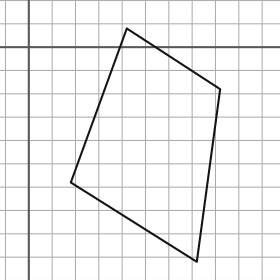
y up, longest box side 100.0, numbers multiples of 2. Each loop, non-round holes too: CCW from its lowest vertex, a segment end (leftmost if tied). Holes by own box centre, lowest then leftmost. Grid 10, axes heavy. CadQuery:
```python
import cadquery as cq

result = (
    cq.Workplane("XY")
    .moveTo(72.0, -92.0)
    .lineTo(82.0, -18.0)
    .lineTo(42.0, 8.0)
    .lineTo(18.0, -58.0)
    .close()
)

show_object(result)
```